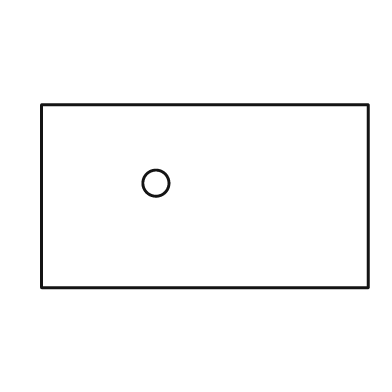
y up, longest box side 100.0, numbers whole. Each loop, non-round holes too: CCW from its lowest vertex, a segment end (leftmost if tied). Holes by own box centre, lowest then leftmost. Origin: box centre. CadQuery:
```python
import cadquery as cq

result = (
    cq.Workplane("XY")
    .moveTo(-50.0, -28.0)
    .lineTo(50.0, -28.0)
    .lineTo(50.0, 28.0)
    .lineTo(-50.0, 28.0)
    .close()
    .moveTo(-15.0, 4.0)
    .circle(4.0)
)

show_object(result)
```